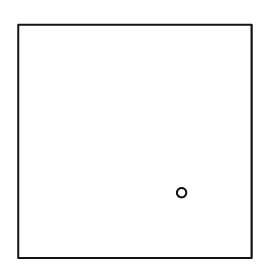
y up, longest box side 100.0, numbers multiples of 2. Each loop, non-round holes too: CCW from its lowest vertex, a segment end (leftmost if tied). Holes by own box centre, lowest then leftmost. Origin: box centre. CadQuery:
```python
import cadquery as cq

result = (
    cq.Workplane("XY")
    .moveTo(-50.0, -50.0)
    .lineTo(50.0, -50.0)
    .lineTo(50.0, 50.0)
    .lineTo(-50.0, 50.0)
    .close()
    .moveTo(20.0, -22.0)
    .circle(2.0)
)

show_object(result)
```